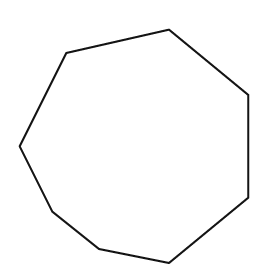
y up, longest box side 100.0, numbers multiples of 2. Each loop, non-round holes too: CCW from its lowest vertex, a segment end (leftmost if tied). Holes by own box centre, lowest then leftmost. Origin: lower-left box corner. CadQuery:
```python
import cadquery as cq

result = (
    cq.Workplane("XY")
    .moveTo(64.0, 0.0)
    .lineTo(98.0, 28.0)
    .lineTo(98.0, 72.0)
    .lineTo(64.0, 100.0)
    .lineTo(20.0, 90.0)
    .lineTo(0.0, 50.0)
    .lineTo(14.0, 22.0)
    .lineTo(34.0, 6.0)
    .close()
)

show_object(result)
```